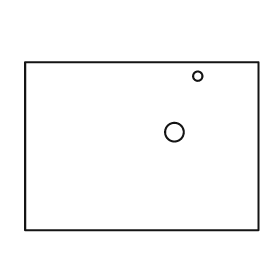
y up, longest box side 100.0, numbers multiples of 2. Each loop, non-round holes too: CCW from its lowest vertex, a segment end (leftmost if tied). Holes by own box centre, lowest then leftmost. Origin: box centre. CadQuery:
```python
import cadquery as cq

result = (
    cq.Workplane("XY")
    .moveTo(-50.0, -36.0)
    .lineTo(50.0, -36.0)
    .lineTo(50.0, 36.0)
    .lineTo(-50.0, 36.0)
    .close()
    .moveTo(14.0, 6.0)
    .circle(4.0)
    .moveTo(24.0, 30.0)
    .circle(2.0)
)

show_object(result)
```